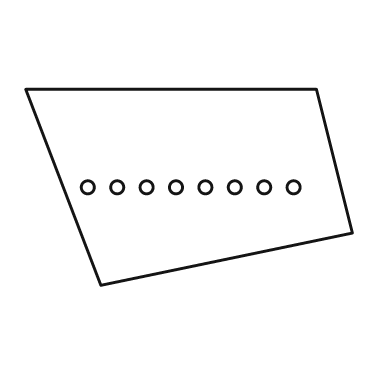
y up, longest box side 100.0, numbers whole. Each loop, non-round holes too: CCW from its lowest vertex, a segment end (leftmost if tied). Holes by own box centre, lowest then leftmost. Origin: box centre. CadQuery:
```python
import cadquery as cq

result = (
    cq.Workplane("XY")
    .moveTo(-27.0, -30.0)
    .lineTo(50.0, -14.0)
    .lineTo(39.0, 30.0)
    .lineTo(-50.0, 30.0)
    .close()
    .moveTo(-31.0, 0.0)
    .circle(2.0)
    .moveTo(-22.0, 0.0)
    .circle(2.0)
    .moveTo(-13.0, 0.0)
    .circle(2.0)
    .moveTo(-4.0, 0.0)
    .circle(2.0)
    .moveTo(5.0, 0.0)
    .circle(2.0)
    .moveTo(14.0, 0.0)
    .circle(2.0)
    .moveTo(23.0, 0.0)
    .circle(2.0)
    .moveTo(32.0, 0.0)
    .circle(2.0)
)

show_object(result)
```